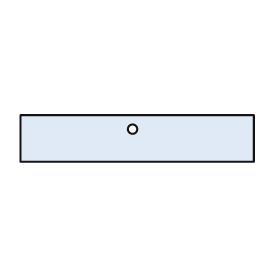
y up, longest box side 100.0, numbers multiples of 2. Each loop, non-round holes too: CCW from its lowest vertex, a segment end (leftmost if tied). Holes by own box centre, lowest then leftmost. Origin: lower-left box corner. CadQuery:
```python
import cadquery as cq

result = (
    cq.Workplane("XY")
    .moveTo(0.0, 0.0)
    .lineTo(100.0, 0.0)
    .lineTo(100.0, 20.0)
    .lineTo(0.0, 20.0)
    .close()
    .moveTo(48.0, 14.0)
    .circle(2.0)
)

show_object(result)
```